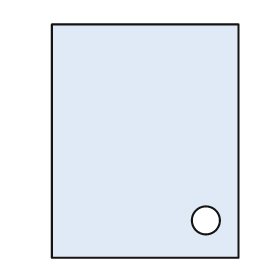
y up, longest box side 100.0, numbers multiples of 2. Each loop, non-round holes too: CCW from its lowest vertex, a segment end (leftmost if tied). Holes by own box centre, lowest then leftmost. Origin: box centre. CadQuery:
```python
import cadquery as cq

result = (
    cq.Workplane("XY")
    .moveTo(-40.0, -50.0)
    .lineTo(40.0, -50.0)
    .lineTo(40.0, 50.0)
    .lineTo(-40.0, 50.0)
    .close()
    .moveTo(26.0, -34.0)
    .circle(6.0)
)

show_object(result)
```